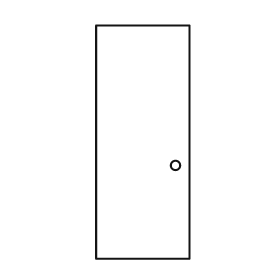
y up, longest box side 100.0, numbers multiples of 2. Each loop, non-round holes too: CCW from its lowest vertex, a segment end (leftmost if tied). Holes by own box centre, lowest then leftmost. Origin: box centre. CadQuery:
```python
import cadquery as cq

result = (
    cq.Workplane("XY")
    .moveTo(-20.0, -50.0)
    .lineTo(20.0, -50.0)
    .lineTo(20.0, 50.0)
    .lineTo(-20.0, 50.0)
    .close()
    .moveTo(14.0, -10.0)
    .circle(2.0)
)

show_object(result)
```